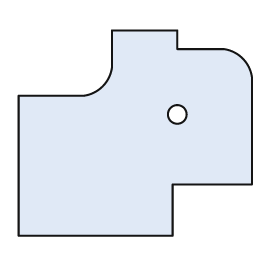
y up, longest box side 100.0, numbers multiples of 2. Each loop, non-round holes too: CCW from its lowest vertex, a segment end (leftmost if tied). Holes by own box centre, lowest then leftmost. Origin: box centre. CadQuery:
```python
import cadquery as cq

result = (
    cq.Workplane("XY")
    .moveTo(-50.0, -44.0)
    .lineTo(16.0, -44.0)
    .lineTo(16.0, -22.0)
    .lineTo(50.0, -22.0)
    .lineTo(50.0, 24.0)
    .threePointArc((46.0, 32.0), (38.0, 36.0))
    .lineTo(18.0, 36.0)
    .lineTo(18.0, 44.0)
    .lineTo(-10.0, 44.0)
    .lineTo(-10.0, 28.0)
    .threePointArc((-14.0, 20.0), (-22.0, 16.0))
    .lineTo(-50.0, 16.0)
    .close()
    .moveTo(18.0, 8.0)
    .circle(4.0)
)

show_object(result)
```